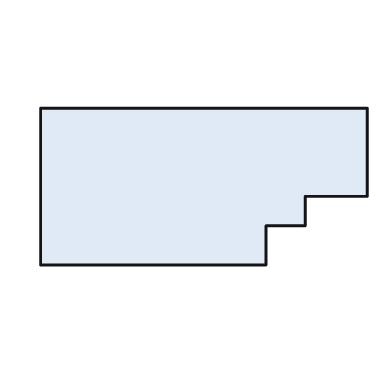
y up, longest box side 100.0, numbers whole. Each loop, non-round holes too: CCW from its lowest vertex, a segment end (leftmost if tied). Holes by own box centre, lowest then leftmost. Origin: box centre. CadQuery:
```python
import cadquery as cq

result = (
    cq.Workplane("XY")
    .moveTo(-50.0, -24.0)
    .lineTo(19.0, -24.0)
    .lineTo(19.0, -12.0)
    .lineTo(31.0, -12.0)
    .lineTo(31.0, -3.0)
    .lineTo(50.0, -3.0)
    .lineTo(50.0, 24.0)
    .lineTo(-50.0, 24.0)
    .close()
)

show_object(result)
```